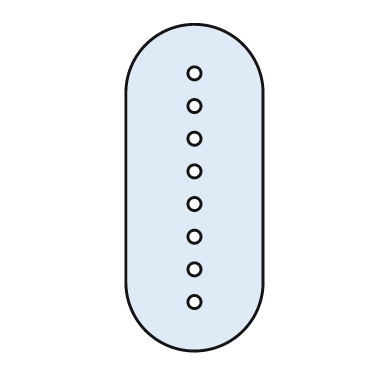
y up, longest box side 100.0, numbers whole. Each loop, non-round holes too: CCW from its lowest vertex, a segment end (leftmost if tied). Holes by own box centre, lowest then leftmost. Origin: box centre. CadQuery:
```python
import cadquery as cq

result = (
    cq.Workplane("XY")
    .moveTo(-21.0, -29.0)
    .threePointArc((0.0, -50.0), (21.0, -29.0))
    .lineTo(21.0, 29.0)
    .threePointArc((0.0, 50.0), (-21.0, 29.0))
    .close()
    .moveTo(0.0, -35.0)
    .circle(2.0)
    .moveTo(0.0, -25.0)
    .circle(2.0)
    .moveTo(0.0, -15.0)
    .circle(2.0)
    .moveTo(0.0, -5.0)
    .circle(2.0)
    .moveTo(0.0, 5.0)
    .circle(2.0)
    .moveTo(0.0, 15.0)
    .circle(2.0)
    .moveTo(0.0, 25.0)
    .circle(2.0)
    .moveTo(0.0, 35.0)
    .circle(2.0)
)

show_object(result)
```